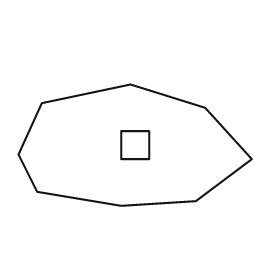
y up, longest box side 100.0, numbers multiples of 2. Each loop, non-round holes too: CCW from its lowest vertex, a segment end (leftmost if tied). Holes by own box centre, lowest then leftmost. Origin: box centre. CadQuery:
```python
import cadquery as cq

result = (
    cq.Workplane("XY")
    .moveTo(-6.0, -26.0)
    .lineTo(26.0, -24.0)
    .lineTo(50.0, -6.0)
    .lineTo(30.0, 16.0)
    .lineTo(-2.0, 26.0)
    .lineTo(-40.0, 18.0)
    .lineTo(-50.0, -4.0)
    .lineTo(-42.0, -20.0)
    .close()
    .moveTo(-6.0, -6.0)
    .lineTo(6.0, -6.0)
    .lineTo(6.0, 6.0)
    .lineTo(-6.0, 6.0)
    .close()
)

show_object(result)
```